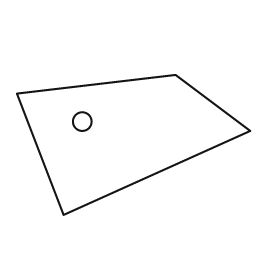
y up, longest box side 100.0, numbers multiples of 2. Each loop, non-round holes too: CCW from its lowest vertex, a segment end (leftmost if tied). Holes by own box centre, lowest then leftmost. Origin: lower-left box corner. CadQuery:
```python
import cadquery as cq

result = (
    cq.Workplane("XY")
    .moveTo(20.0, 0.0)
    .lineTo(100.0, 36.0)
    .lineTo(68.0, 60.0)
    .lineTo(0.0, 52.0)
    .close()
    .moveTo(28.0, 40.0)
    .circle(4.0)
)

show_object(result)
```